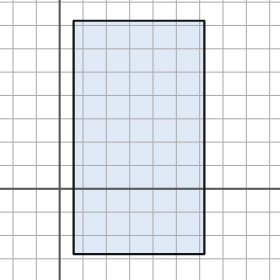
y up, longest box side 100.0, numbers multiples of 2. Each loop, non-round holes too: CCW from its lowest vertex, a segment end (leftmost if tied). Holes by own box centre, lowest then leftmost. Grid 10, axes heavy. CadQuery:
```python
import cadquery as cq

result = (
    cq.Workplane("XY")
    .moveTo(6.0, -28.0)
    .lineTo(62.0, -28.0)
    .lineTo(62.0, 72.0)
    .lineTo(6.0, 72.0)
    .close()
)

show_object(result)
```